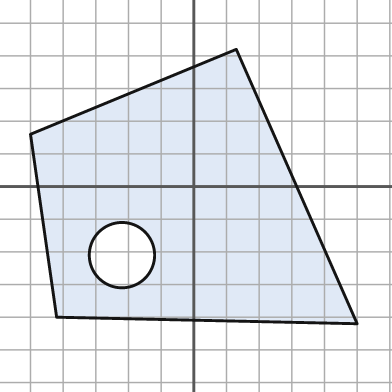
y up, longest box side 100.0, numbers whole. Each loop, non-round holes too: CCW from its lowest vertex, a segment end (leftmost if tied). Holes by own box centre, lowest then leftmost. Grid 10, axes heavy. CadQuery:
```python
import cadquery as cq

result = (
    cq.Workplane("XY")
    .moveTo(50.0, -42.0)
    .lineTo(13.0, 42.0)
    .lineTo(-50.0, 16.0)
    .lineTo(-42.0, -40.0)
    .close()
    .moveTo(-22.0, -21.0)
    .circle(10.0)
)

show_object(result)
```